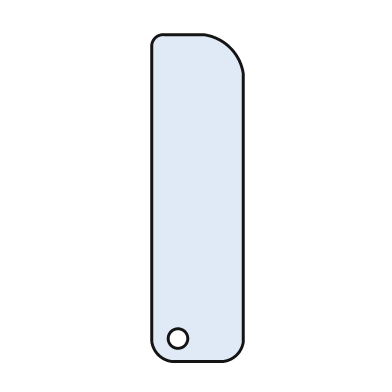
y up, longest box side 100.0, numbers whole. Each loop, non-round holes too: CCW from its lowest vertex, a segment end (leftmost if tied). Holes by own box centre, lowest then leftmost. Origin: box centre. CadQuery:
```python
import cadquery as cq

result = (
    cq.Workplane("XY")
    .moveTo(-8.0, -50.0)
    .lineTo(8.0, -50.0)
    .threePointArc((12.0, -48.0), (14.0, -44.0))
    .lineTo(14.0, 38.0)
    .threePointArc((10.0, 46.0), (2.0, 50.0))
    .lineTo(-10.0, 50.0)
    .threePointArc((-13.0, 49.0), (-14.0, 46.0))
    .lineTo(-14.0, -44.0)
    .threePointArc((-12.0, -48.0), (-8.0, -50.0))
    .close()
    .moveTo(-6.0, -43.0)
    .circle(3.0)
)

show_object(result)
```